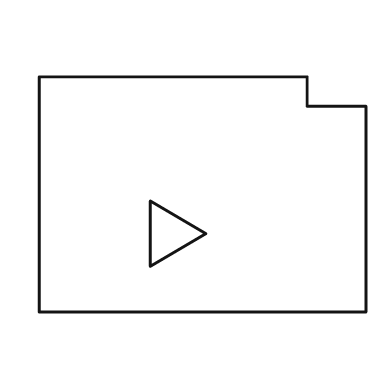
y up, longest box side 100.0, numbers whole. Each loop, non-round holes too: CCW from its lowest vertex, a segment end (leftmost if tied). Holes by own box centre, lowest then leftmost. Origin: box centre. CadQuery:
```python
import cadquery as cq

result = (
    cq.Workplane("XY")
    .moveTo(-50.0, -36.0)
    .lineTo(50.0, -36.0)
    .lineTo(50.0, 27.0)
    .lineTo(32.0, 27.0)
    .lineTo(32.0, 36.0)
    .lineTo(-50.0, 36.0)
    .close()
    .moveTo(-16.0, -22.0)
    .lineTo(1.0, -12.0)
    .lineTo(-16.0, -2.0)
    .close()
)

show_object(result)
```